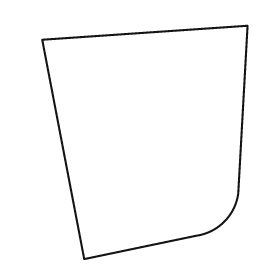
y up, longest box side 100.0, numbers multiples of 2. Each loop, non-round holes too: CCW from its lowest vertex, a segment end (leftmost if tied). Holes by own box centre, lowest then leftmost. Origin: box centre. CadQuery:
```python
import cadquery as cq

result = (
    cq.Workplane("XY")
    .moveTo(-26.0, -50.0)
    .lineTo(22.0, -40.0)
    .threePointArc((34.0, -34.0), (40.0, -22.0))
    .lineTo(44.0, 50.0)
    .lineTo(-44.0, 44.0)
    .close()
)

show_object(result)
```